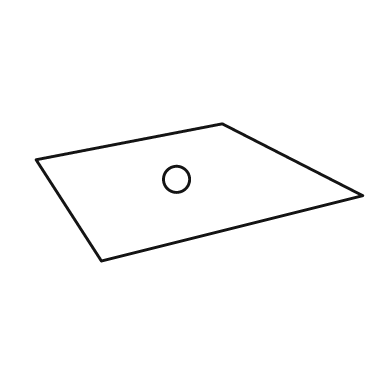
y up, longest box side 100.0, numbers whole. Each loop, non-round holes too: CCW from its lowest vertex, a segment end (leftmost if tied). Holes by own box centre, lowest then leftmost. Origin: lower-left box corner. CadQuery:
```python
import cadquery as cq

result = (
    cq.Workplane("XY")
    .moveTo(20.0, 0.0)
    .lineTo(100.0, 20.0)
    .lineTo(57.0, 42.0)
    .lineTo(0.0, 31.0)
    .close()
    .moveTo(43.0, 25.0)
    .circle(4.0)
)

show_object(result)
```